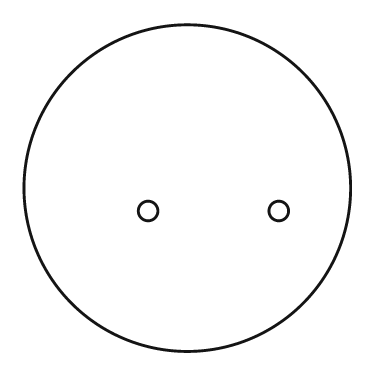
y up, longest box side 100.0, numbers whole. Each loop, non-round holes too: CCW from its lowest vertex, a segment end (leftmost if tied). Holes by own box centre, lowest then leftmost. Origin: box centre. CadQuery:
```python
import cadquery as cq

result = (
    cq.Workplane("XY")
    .moveTo(0.0, 0.0)
    .circle(50.0)
    .moveTo(-12.0, -7.0)
    .circle(3.0)
    .moveTo(28.0, -7.0)
    .circle(3.0)
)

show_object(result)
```